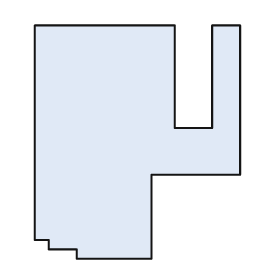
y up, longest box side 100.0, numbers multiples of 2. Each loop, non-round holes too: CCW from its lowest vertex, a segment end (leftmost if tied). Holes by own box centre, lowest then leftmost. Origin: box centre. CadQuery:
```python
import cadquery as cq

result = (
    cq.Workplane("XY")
    .moveTo(-26.0, -50.0)
    .lineTo(6.0, -50.0)
    .lineTo(6.0, -14.0)
    .lineTo(44.0, -14.0)
    .lineTo(44.0, 50.0)
    .lineTo(32.0, 50.0)
    .lineTo(32.0, 6.0)
    .lineTo(16.0, 6.0)
    .lineTo(16.0, 50.0)
    .lineTo(-44.0, 50.0)
    .lineTo(-44.0, -42.0)
    .lineTo(-38.0, -42.0)
    .lineTo(-38.0, -46.0)
    .lineTo(-26.0, -46.0)
    .close()
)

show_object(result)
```